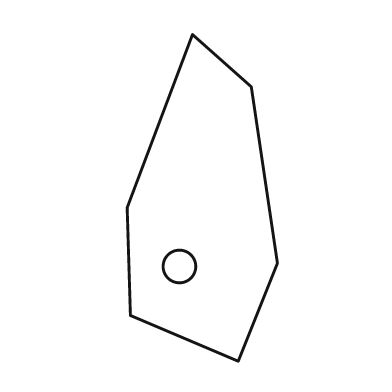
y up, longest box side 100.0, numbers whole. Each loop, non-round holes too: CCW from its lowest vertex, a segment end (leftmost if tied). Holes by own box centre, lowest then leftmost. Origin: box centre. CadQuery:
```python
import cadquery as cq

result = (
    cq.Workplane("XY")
    .moveTo(11.0, -50.0)
    .lineTo(23.0, -20.0)
    .lineTo(15.0, 34.0)
    .lineTo(-3.0, 50.0)
    .lineTo(-23.0, -3.0)
    .lineTo(-22.0, -36.0)
    .close()
    .moveTo(-7.0, -21.0)
    .circle(5.0)
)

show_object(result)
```